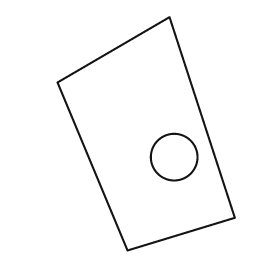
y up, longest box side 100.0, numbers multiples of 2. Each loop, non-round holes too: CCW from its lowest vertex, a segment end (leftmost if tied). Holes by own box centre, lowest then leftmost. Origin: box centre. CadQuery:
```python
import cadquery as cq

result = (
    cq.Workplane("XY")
    .moveTo(-8.0, -50.0)
    .lineTo(38.0, -36.0)
    .lineTo(10.0, 50.0)
    .lineTo(-38.0, 22.0)
    .close()
    .moveTo(12.0, -10.0)
    .circle(10.0)
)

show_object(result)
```